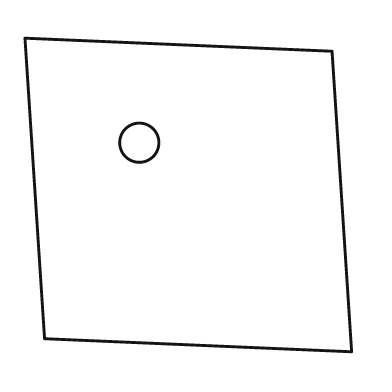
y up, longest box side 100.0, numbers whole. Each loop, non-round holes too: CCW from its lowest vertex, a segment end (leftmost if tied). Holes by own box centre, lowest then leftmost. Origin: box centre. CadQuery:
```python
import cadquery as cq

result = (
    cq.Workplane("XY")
    .moveTo(50.0, -48.0)
    .lineTo(44.0, 44.0)
    .lineTo(-50.0, 48.0)
    .lineTo(-44.0, -44.0)
    .close()
    .moveTo(-15.0, 16.0)
    .circle(6.0)
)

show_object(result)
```